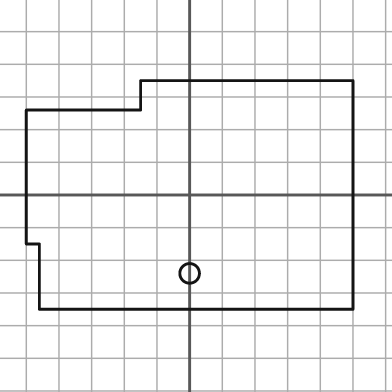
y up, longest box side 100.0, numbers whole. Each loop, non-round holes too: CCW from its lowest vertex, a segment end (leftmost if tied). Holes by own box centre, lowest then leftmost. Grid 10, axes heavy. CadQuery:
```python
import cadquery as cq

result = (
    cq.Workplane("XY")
    .moveTo(-46.0, -35.0)
    .lineTo(50.0, -35.0)
    .lineTo(50.0, 35.0)
    .lineTo(-15.0, 35.0)
    .lineTo(-15.0, 26.0)
    .lineTo(-50.0, 26.0)
    .lineTo(-50.0, -15.0)
    .lineTo(-46.0, -15.0)
    .close()
    .moveTo(0.0, -24.0)
    .circle(3.0)
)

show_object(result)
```